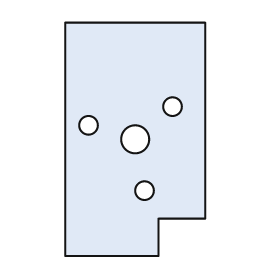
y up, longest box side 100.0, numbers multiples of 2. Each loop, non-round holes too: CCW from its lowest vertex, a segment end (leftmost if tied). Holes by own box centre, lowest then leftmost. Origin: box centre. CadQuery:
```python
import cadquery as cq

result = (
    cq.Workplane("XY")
    .moveTo(-30.0, -50.0)
    .lineTo(10.0, -50.0)
    .lineTo(10.0, -34.0)
    .lineTo(30.0, -34.0)
    .lineTo(30.0, 50.0)
    .lineTo(-30.0, 50.0)
    .close()
    .moveTo(4.0, -22.0)
    .circle(4.0)
    .moveTo(0.0, 0.0)
    .circle(6.0)
    .moveTo(-20.0, 6.0)
    .circle(4.0)
    .moveTo(16.0, 14.0)
    .circle(4.0)
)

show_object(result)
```